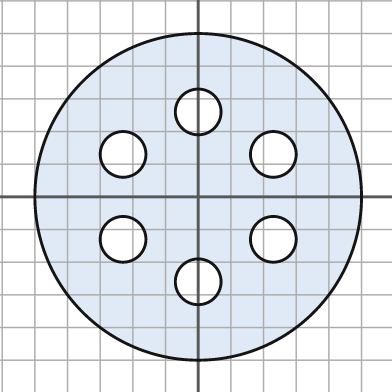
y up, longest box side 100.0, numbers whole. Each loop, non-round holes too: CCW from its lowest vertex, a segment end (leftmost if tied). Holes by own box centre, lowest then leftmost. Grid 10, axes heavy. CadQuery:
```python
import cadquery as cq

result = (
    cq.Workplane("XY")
    .moveTo(0.0, 0.0)
    .circle(50.0)
    .moveTo(0.0, -26.0)
    .circle(7.0)
    .moveTo(-23.0, -13.0)
    .circle(7.0)
    .moveTo(23.0, -13.0)
    .circle(7.0)
    .moveTo(-23.0, 13.0)
    .circle(7.0)
    .moveTo(23.0, 13.0)
    .circle(7.0)
    .moveTo(0.0, 26.0)
    .circle(7.0)
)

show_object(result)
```